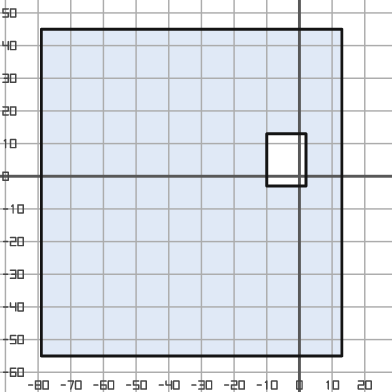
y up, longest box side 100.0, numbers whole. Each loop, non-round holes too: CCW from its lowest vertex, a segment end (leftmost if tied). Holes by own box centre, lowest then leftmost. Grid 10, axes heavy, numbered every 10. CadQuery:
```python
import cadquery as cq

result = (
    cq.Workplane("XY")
    .moveTo(-79.0, -55.0)
    .lineTo(13.0, -55.0)
    .lineTo(13.0, 45.0)
    .lineTo(-79.0, 45.0)
    .close()
    .moveTo(-10.0, -3.0)
    .lineTo(2.0, -3.0)
    .lineTo(2.0, 13.0)
    .lineTo(-10.0, 13.0)
    .close()
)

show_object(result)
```